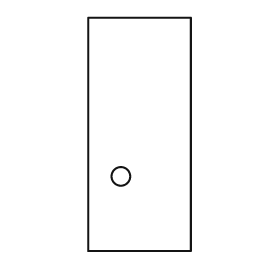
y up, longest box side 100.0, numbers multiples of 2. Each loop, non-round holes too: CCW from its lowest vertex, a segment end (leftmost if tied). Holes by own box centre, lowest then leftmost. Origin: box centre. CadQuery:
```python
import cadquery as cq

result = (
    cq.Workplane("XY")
    .moveTo(-22.0, -50.0)
    .lineTo(22.0, -50.0)
    .lineTo(22.0, 50.0)
    .lineTo(-22.0, 50.0)
    .close()
    .moveTo(-8.0, -18.0)
    .circle(4.0)
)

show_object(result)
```